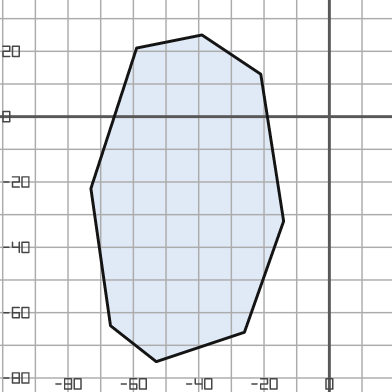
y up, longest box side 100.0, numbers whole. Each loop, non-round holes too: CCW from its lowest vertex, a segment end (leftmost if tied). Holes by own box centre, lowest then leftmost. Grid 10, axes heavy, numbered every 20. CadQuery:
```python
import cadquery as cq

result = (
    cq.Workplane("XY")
    .moveTo(-53.0, -75.0)
    .lineTo(-26.0, -66.0)
    .lineTo(-14.0, -32.0)
    .lineTo(-21.0, 13.0)
    .lineTo(-39.0, 25.0)
    .lineTo(-59.0, 21.0)
    .lineTo(-73.0, -22.0)
    .lineTo(-67.0, -64.0)
    .close()
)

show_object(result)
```